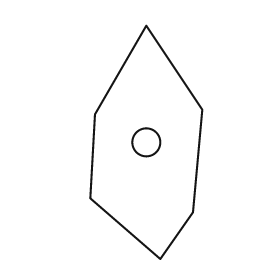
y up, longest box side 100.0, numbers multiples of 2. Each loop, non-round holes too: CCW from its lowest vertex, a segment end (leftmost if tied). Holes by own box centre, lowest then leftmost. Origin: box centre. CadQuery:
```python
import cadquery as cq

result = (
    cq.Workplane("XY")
    .moveTo(6.0, -50.0)
    .lineTo(20.0, -30.0)
    .lineTo(24.0, 14.0)
    .lineTo(0.0, 50.0)
    .lineTo(-22.0, 12.0)
    .lineTo(-24.0, -24.0)
    .close()
    .moveTo(0.0, 0.0)
    .circle(6.0)
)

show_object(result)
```